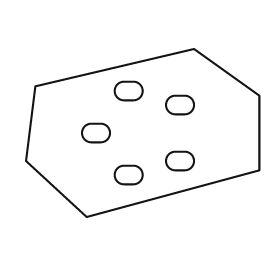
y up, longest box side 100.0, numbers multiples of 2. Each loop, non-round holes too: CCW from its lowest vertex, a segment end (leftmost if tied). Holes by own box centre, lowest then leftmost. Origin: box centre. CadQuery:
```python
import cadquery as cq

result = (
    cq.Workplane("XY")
    .moveTo(-24.0, -36.0)
    .lineTo(50.0, -16.0)
    .lineTo(50.0, 16.0)
    .lineTo(22.0, 36.0)
    .lineTo(-46.0, 20.0)
    .lineTo(-50.0, -12.0)
    .close()
    .moveTo(-8.0, -22.0)
    .lineTo(-4.0, -22.0)
    .threePointArc((0.0, -18.0), (-4.0, -14.0))
    .lineTo(-8.0, -14.0)
    .threePointArc((-12.0, -18.0), (-8.0, -22.0))
    .close()
    .moveTo(14.0, -16.0)
    .lineTo(18.0, -16.0)
    .threePointArc((22.0, -12.0), (18.0, -8.0))
    .lineTo(14.0, -8.0)
    .threePointArc((10.0, -12.0), (14.0, -16.0))
    .close()
    .moveTo(-22.0, -4.0)
    .lineTo(-18.0, -4.0)
    .threePointArc((-14.0, 0.0), (-18.0, 4.0))
    .lineTo(-22.0, 4.0)
    .threePointArc((-26.0, 0.0), (-22.0, -4.0))
    .close()
    .moveTo(14.0, 8.0)
    .lineTo(18.0, 8.0)
    .threePointArc((22.0, 12.0), (18.0, 16.0))
    .lineTo(14.0, 16.0)
    .threePointArc((10.0, 12.0), (14.0, 8.0))
    .close()
    .moveTo(-8.0, 14.0)
    .lineTo(-4.0, 14.0)
    .threePointArc((0.0, 18.0), (-4.0, 22.0))
    .lineTo(-8.0, 22.0)
    .threePointArc((-12.0, 18.0), (-8.0, 14.0))
    .close()
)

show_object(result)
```